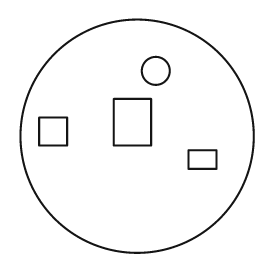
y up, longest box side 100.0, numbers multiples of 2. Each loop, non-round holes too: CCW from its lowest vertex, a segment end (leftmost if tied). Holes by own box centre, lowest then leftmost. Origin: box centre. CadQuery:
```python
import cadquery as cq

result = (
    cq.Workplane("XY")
    .moveTo(0.0, 0.0)
    .circle(50.0)
    .moveTo(22.0, -14.0)
    .lineTo(34.0, -14.0)
    .lineTo(34.0, -6.0)
    .lineTo(22.0, -6.0)
    .close()
    .moveTo(-42.0, -4.0)
    .lineTo(-30.0, -4.0)
    .lineTo(-30.0, 8.0)
    .lineTo(-42.0, 8.0)
    .close()
    .moveTo(-10.0, -4.0)
    .lineTo(6.0, -4.0)
    .lineTo(6.0, 16.0)
    .lineTo(-10.0, 16.0)
    .close()
    .moveTo(8.0, 28.0)
    .circle(6.0)
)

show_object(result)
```